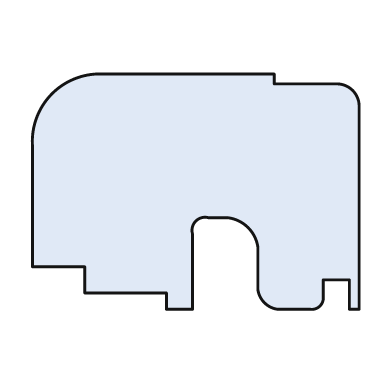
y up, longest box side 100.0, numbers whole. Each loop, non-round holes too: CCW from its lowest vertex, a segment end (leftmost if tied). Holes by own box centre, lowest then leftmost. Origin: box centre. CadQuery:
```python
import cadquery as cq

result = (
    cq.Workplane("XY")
    .moveTo(-9.0, -36.0)
    .lineTo(-1.0, -36.0)
    .lineTo(-1.0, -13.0)
    .threePointArc((0.0, -9.0), (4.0, -8.0))
    .lineTo(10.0, -8.0)
    .threePointArc((16.0, -11.0), (19.0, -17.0))
    .lineTo(19.0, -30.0)
    .threePointArc((21.0, -34.0), (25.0, -36.0))
    .lineTo(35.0, -36.0)
    .threePointArc((38.0, -35.0), (39.0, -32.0))
    .lineTo(39.0, -27.0)
    .lineTo(47.0, -27.0)
    .lineTo(47.0, -36.0)
    .lineTo(50.0, -36.0)
    .lineTo(50.0, 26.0)
    .threePointArc((48.0, 31.0), (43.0, 33.0))
    .lineTo(24.0, 33.0)
    .lineTo(24.0, 36.0)
    .lineTo(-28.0, 36.0)
    .threePointArc((-44.0, 30.0), (-50.0, 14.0))
    .lineTo(-50.0, -23.0)
    .lineTo(-34.0, -23.0)
    .lineTo(-34.0, -31.0)
    .lineTo(-9.0, -31.0)
    .close()
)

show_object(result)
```